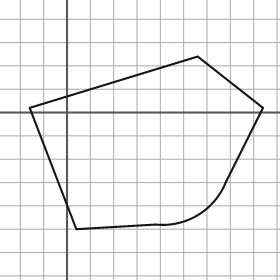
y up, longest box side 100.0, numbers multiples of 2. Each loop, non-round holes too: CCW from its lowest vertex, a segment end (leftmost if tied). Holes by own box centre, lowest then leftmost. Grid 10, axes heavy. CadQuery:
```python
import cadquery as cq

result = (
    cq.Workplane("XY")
    .moveTo(4.0, -50.0)
    .lineTo(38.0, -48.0)
    .threePointArc((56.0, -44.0), (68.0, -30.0))
    .lineTo(84.0, 2.0)
    .lineTo(56.0, 24.0)
    .lineTo(-16.0, 2.0)
    .close()
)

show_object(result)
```